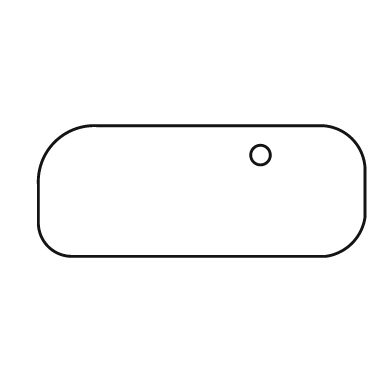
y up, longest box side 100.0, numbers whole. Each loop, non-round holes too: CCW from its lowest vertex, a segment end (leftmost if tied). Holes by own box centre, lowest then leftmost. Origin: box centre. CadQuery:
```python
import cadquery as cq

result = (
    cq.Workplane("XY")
    .moveTo(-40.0, -20.0)
    .lineTo(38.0, -20.0)
    .threePointArc((46.0, -16.0), (50.0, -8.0))
    .lineTo(50.0, 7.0)
    .threePointArc((46.0, 16.0), (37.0, 20.0))
    .lineTo(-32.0, 20.0)
    .threePointArc((-45.0, 15.0), (-50.0, 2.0))
    .lineTo(-50.0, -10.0)
    .threePointArc((-47.0, -17.0), (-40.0, -20.0))
    .close()
    .moveTo(18.0, 11.0)
    .circle(3.0)
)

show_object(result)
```